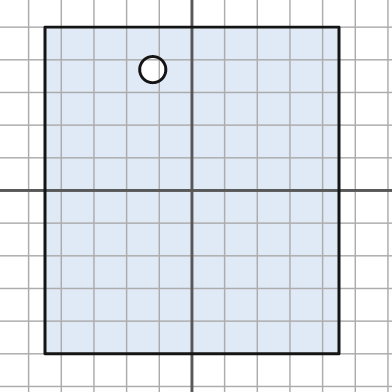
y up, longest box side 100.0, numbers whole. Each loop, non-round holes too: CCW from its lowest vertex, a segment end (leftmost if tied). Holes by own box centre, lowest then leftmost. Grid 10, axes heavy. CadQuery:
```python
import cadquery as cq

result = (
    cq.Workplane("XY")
    .moveTo(-45.0, -50.0)
    .lineTo(45.0, -50.0)
    .lineTo(45.0, 50.0)
    .lineTo(-45.0, 50.0)
    .close()
    .moveTo(-12.0, 37.0)
    .circle(4.0)
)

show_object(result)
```